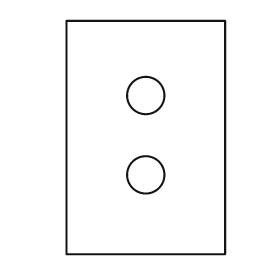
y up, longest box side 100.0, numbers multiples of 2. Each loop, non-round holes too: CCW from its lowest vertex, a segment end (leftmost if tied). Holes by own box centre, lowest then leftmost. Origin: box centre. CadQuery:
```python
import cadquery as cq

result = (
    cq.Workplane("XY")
    .moveTo(-34.0, -50.0)
    .lineTo(34.0, -50.0)
    .lineTo(34.0, 50.0)
    .lineTo(-34.0, 50.0)
    .close()
    .moveTo(0.0, -16.0)
    .circle(8.0)
    .moveTo(0.0, 18.0)
    .circle(8.0)
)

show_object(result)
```